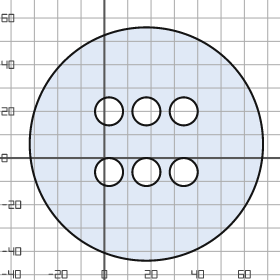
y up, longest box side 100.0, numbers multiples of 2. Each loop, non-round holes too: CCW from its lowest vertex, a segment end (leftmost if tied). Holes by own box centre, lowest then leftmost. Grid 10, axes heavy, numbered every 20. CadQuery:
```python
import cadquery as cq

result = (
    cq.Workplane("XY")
    .moveTo(18.0, 6.0)
    .circle(50.0)
    .moveTo(2.0, -6.0)
    .circle(6.0)
    .moveTo(18.0, -6.0)
    .circle(6.0)
    .moveTo(34.0, -6.0)
    .circle(6.0)
    .moveTo(2.0, 20.0)
    .circle(6.0)
    .moveTo(18.0, 20.0)
    .circle(6.0)
    .moveTo(34.0, 20.0)
    .circle(6.0)
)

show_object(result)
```